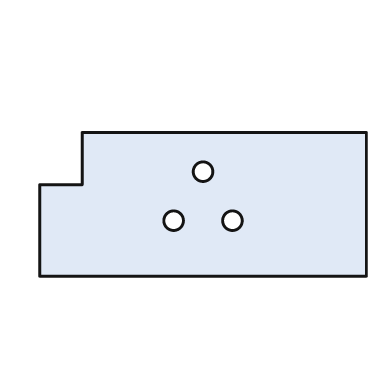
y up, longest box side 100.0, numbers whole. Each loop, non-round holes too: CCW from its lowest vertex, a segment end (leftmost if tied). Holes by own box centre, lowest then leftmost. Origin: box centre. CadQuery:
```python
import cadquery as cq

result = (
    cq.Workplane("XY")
    .moveTo(-50.0, -22.0)
    .lineTo(50.0, -22.0)
    .lineTo(50.0, 22.0)
    .lineTo(-37.0, 22.0)
    .lineTo(-37.0, 6.0)
    .lineTo(-50.0, 6.0)
    .close()
    .moveTo(-9.0, -5.0)
    .circle(3.0)
    .moveTo(9.0, -5.0)
    .circle(3.0)
    .moveTo(0.0, 10.0)
    .circle(3.0)
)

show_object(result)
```